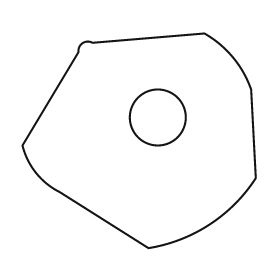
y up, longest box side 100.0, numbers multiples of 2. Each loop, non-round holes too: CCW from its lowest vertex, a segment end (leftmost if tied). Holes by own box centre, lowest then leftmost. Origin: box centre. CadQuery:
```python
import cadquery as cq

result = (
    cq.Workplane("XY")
    .moveTo(4.0, -46.0)
    .threePointArc((30.0, -36.0), (50.0, -16.0))
    .lineTo(48.0, 22.0)
    .threePointArc((40.0, 36.0), (28.0, 46.0))
    .lineTo(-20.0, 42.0)
    .threePointArc((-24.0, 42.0), (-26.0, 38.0))
    .lineTo(-50.0, -2.0)
    .threePointArc((-44.0, -14.0), (-34.0, -22.0))
    .close()
    .moveTo(8.0, 10.0)
    .circle(12.0)
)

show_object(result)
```